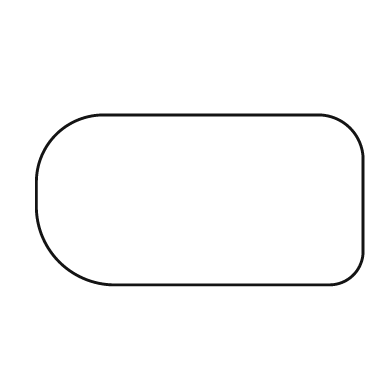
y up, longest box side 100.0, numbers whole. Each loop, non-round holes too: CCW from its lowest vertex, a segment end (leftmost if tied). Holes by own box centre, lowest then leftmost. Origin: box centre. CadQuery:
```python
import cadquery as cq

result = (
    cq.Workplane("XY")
    .moveTo(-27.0, -26.0)
    .lineTo(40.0, -26.0)
    .threePointArc((47.0, -23.0), (50.0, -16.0))
    .lineTo(50.0, 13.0)
    .threePointArc((46.0, 22.0), (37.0, 26.0))
    .lineTo(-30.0, 26.0)
    .threePointArc((-44.0, 20.0), (-50.0, 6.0))
    .lineTo(-50.0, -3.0)
    .threePointArc((-43.0, -19.0), (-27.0, -26.0))
    .close()
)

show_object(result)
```